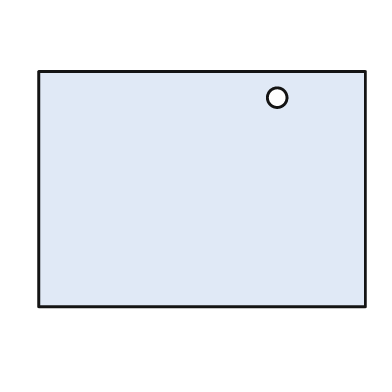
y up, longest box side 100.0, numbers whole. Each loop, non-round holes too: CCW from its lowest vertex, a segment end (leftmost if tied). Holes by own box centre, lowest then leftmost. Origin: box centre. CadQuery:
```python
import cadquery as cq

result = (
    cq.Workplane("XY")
    .moveTo(-50.0, -36.0)
    .lineTo(50.0, -36.0)
    .lineTo(50.0, 36.0)
    .lineTo(-50.0, 36.0)
    .close()
    .moveTo(23.0, 28.0)
    .circle(3.0)
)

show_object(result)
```